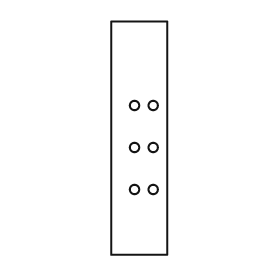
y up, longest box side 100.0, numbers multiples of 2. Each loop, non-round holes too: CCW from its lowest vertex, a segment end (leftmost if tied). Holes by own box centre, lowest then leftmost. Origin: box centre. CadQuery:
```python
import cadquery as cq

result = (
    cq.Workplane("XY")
    .moveTo(-12.0, -50.0)
    .lineTo(12.0, -50.0)
    .lineTo(12.0, 50.0)
    .lineTo(-12.0, 50.0)
    .close()
    .moveTo(-2.0, -22.0)
    .circle(2.0)
    .moveTo(6.0, -22.0)
    .circle(2.0)
    .moveTo(-2.0, -4.0)
    .circle(2.0)
    .moveTo(6.0, -4.0)
    .circle(2.0)
    .moveTo(-2.0, 14.0)
    .circle(2.0)
    .moveTo(6.0, 14.0)
    .circle(2.0)
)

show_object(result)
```